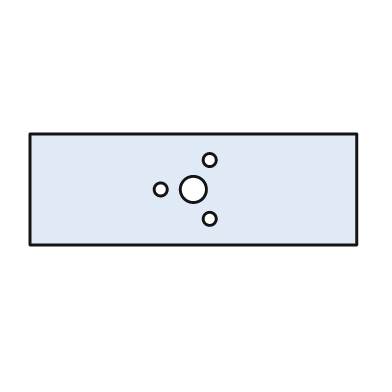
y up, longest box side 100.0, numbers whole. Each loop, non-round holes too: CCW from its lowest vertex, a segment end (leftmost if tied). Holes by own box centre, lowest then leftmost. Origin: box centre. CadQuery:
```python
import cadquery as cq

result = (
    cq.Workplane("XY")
    .moveTo(-50.0, -17.0)
    .lineTo(50.0, -17.0)
    .lineTo(50.0, 17.0)
    .lineTo(-50.0, 17.0)
    .close()
    .moveTo(5.0, -9.0)
    .circle(2.0)
    .moveTo(-10.0, 0.0)
    .circle(2.0)
    .moveTo(0.0, 0.0)
    .circle(4.0)
    .moveTo(5.0, 9.0)
    .circle(2.0)
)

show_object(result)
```